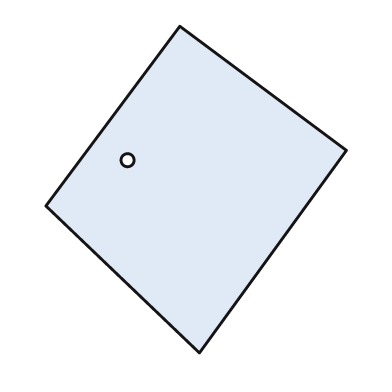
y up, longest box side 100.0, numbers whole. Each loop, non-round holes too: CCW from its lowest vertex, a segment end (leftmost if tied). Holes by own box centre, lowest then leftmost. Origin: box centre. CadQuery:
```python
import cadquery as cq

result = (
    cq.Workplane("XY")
    .moveTo(1.0, -50.0)
    .lineTo(46.0, 12.0)
    .lineTo(-5.0, 50.0)
    .lineTo(-46.0, -5.0)
    .close()
    .moveTo(-21.0, 9.0)
    .circle(2.0)
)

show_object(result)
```